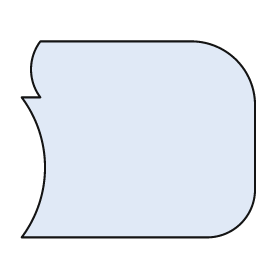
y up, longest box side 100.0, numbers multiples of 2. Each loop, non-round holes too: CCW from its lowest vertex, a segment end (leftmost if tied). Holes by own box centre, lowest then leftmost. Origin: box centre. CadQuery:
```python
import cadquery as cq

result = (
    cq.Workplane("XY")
    .moveTo(-50.0, -42.0)
    .lineTo(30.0, -42.0)
    .threePointArc((44.0, -36.0), (50.0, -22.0))
    .lineTo(50.0, 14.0)
    .threePointArc((42.0, 34.0), (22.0, 42.0))
    .lineTo(-42.0, 42.0)
    .threePointArc((-46.0, 30.0), (-42.0, 18.0))
    .lineTo(-50.0, 18.0)
    .threePointArc((-40.0, -12.0), (-50.0, -42.0))
    .close()
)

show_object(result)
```